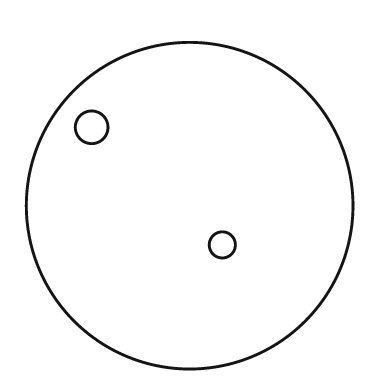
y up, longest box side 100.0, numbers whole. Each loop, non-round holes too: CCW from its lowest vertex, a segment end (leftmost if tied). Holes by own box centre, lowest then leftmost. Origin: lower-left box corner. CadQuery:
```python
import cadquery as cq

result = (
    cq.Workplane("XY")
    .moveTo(50.0, 50.0)
    .circle(50.0)
    .moveTo(60.0, 38.0)
    .circle(4.0)
    .moveTo(20.0, 74.0)
    .circle(5.0)
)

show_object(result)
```